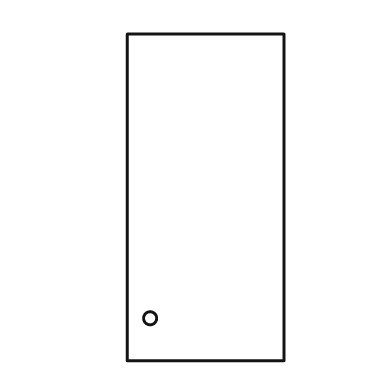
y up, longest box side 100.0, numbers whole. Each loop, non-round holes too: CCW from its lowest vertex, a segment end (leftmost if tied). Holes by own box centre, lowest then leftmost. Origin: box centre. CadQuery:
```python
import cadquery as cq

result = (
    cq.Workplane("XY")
    .moveTo(-24.0, -50.0)
    .lineTo(24.0, -50.0)
    .lineTo(24.0, 50.0)
    .lineTo(-24.0, 50.0)
    .close()
    .moveTo(-17.0, -37.0)
    .circle(2.0)
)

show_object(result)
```